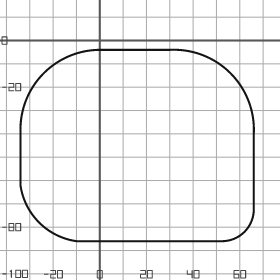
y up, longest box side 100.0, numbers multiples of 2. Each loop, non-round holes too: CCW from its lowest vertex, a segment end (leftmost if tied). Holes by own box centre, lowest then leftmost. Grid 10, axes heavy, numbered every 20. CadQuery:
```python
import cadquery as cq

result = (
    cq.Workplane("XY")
    .moveTo(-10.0, -86.0)
    .lineTo(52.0, -86.0)
    .threePointArc((62.0, -82.0), (66.0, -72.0))
    .lineTo(66.0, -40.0)
    .threePointArc((56.0, -14.0), (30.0, -4.0))
    .lineTo(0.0, -4.0)
    .threePointArc((-24.0, -14.0), (-34.0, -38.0))
    .lineTo(-34.0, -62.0)
    .threePointArc((-26.0, -78.0), (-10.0, -86.0))
    .close()
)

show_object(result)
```